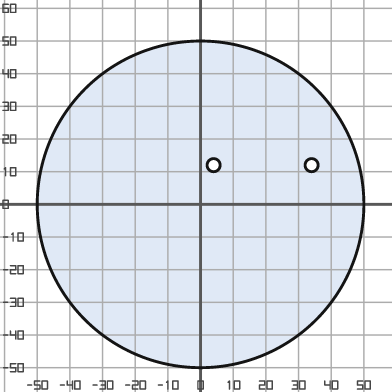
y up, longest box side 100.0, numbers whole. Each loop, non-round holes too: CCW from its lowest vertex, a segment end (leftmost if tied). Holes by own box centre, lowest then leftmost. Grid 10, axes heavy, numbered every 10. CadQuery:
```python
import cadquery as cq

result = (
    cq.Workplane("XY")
    .moveTo(0.0, 0.0)
    .circle(50.0)
    .moveTo(4.0, 12.0)
    .circle(2.0)
    .moveTo(34.0, 12.0)
    .circle(2.0)
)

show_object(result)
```